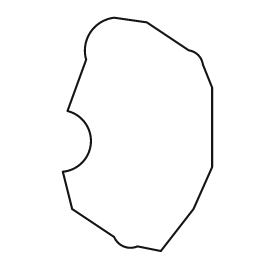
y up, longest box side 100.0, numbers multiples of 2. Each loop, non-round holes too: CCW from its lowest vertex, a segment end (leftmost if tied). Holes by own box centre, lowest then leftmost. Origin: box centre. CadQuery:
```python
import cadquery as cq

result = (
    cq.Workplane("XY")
    .moveTo(10.0, -50.0)
    .lineTo(24.0, -32.0)
    .lineTo(32.0, -14.0)
    .lineTo(32.0, 20.0)
    .lineTo(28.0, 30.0)
    .threePointArc((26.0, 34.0), (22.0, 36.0))
    .lineTo(4.0, 48.0)
    .lineTo(-10.0, 50.0)
    .threePointArc((-20.0, 44.0), (-22.0, 32.0))
    .lineTo(-30.0, 10.0)
    .threePointArc((-20.0, -4.0), (-32.0, -16.0))
    .lineTo(-28.0, -32.0)
    .lineTo(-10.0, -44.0)
    .threePointArc((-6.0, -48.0), (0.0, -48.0))
    .close()
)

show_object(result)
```